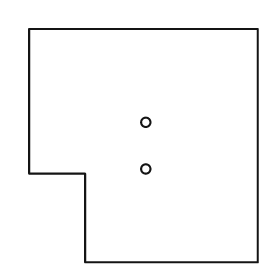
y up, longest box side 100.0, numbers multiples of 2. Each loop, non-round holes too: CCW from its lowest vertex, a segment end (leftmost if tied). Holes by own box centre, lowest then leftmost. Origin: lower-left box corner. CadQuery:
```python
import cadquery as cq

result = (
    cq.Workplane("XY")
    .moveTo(24.0, 0.0)
    .lineTo(98.0, 0.0)
    .lineTo(98.0, 100.0)
    .lineTo(0.0, 100.0)
    .lineTo(0.0, 38.0)
    .lineTo(24.0, 38.0)
    .close()
    .moveTo(50.0, 40.0)
    .circle(2.0)
    .moveTo(50.0, 60.0)
    .circle(2.0)
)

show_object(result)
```